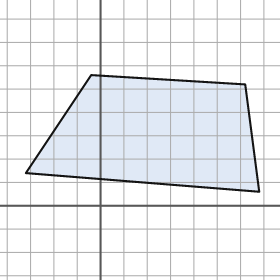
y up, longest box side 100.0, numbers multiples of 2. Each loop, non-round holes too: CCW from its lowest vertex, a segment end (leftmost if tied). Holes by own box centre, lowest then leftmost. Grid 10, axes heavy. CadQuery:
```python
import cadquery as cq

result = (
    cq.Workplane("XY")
    .moveTo(68.0, 6.0)
    .lineTo(62.0, 52.0)
    .lineTo(-4.0, 56.0)
    .lineTo(-32.0, 14.0)
    .close()
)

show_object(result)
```